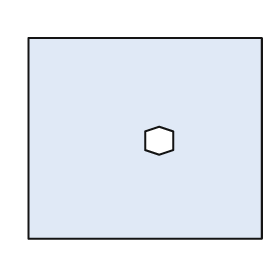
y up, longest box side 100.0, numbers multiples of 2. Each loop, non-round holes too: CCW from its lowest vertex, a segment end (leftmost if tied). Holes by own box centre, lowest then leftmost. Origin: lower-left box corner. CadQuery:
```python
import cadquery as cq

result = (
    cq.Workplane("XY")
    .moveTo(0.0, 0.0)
    .lineTo(100.0, 0.0)
    .lineTo(100.0, 86.0)
    .lineTo(0.0, 86.0)
    .close()
    .moveTo(56.0, 36.0)
    .lineTo(62.0, 38.0)
    .lineTo(62.0, 46.0)
    .lineTo(56.0, 48.0)
    .lineTo(50.0, 46.0)
    .lineTo(50.0, 38.0)
    .close()
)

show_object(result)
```